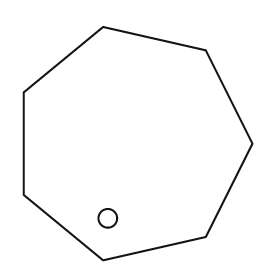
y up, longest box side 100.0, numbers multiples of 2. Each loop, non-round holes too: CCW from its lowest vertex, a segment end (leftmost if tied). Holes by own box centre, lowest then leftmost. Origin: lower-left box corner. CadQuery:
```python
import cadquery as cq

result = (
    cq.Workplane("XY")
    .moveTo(34.0, 0.0)
    .lineTo(78.0, 10.0)
    .lineTo(98.0, 50.0)
    .lineTo(78.0, 90.0)
    .lineTo(34.0, 100.0)
    .lineTo(0.0, 72.0)
    .lineTo(0.0, 28.0)
    .close()
    .moveTo(36.0, 18.0)
    .circle(4.0)
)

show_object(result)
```